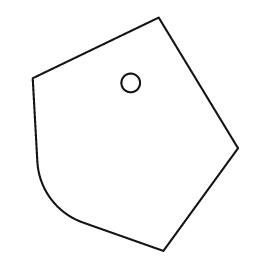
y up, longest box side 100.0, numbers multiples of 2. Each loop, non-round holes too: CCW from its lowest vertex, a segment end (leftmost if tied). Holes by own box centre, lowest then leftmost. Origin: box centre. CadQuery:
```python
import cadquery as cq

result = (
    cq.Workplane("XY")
    .moveTo(12.0, -50.0)
    .lineTo(44.0, -6.0)
    .lineTo(10.0, 50.0)
    .lineTo(-44.0, 24.0)
    .lineTo(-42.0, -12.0)
    .threePointArc((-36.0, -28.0), (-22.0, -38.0))
    .close()
    .moveTo(-2.0, 22.0)
    .circle(4.0)
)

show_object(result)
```